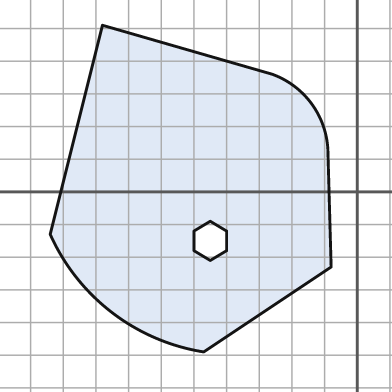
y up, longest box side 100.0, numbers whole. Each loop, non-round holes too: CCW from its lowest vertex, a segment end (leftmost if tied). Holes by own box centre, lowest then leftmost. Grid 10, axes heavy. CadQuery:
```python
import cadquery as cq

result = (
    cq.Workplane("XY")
    .moveTo(-47.0, -49.0)
    .lineTo(-8.0, -23.0)
    .lineTo(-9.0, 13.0)
    .threePointArc((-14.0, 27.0), (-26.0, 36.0))
    .lineTo(-78.0, 51.0)
    .lineTo(-94.0, -13.0)
    .threePointArc((-75.0, -37.0), (-47.0, -49.0))
    .close()
    .moveTo(-45.0, -21.0)
    .lineTo(-40.0, -18.0)
    .lineTo(-40.0, -12.0)
    .lineTo(-45.0, -9.0)
    .lineTo(-50.0, -12.0)
    .lineTo(-50.0, -18.0)
    .close()
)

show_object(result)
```